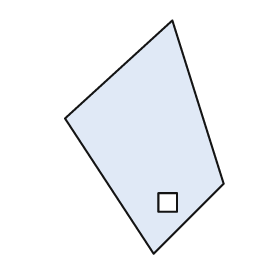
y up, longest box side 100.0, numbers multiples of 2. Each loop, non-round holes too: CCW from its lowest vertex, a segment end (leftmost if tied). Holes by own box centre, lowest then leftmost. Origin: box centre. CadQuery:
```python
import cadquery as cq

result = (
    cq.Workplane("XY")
    .moveTo(4.0, -50.0)
    .lineTo(34.0, -20.0)
    .lineTo(12.0, 50.0)
    .lineTo(-34.0, 8.0)
    .close()
    .moveTo(6.0, -32.0)
    .lineTo(14.0, -32.0)
    .lineTo(14.0, -24.0)
    .lineTo(6.0, -24.0)
    .close()
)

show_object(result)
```